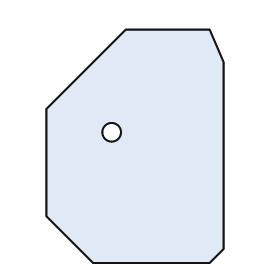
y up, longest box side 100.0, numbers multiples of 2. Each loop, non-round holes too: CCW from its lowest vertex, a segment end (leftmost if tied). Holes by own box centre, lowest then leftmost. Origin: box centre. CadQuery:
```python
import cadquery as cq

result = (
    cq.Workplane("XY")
    .moveTo(-18.0, -50.0)
    .lineTo(32.0, -50.0)
    .lineTo(38.0, -44.0)
    .lineTo(38.0, 36.0)
    .lineTo(32.0, 50.0)
    .lineTo(-4.0, 50.0)
    .lineTo(-38.0, 16.0)
    .lineTo(-38.0, -30.0)
    .close()
    .moveTo(-10.0, 6.0)
    .circle(4.0)
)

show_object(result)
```